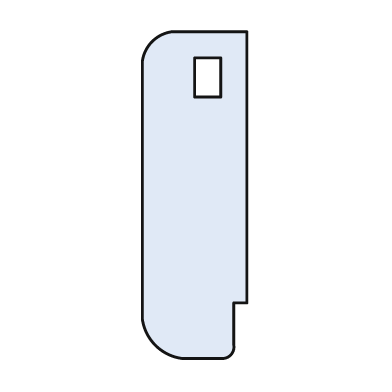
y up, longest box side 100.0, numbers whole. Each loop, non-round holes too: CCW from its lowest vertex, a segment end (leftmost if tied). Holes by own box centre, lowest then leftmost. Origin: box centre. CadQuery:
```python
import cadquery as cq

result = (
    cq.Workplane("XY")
    .moveTo(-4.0, -50.0)
    .lineTo(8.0, -50.0)
    .threePointArc((11.0, -49.0), (12.0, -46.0))
    .lineTo(12.0, -33.0)
    .lineTo(16.0, -33.0)
    .lineTo(16.0, 50.0)
    .lineTo(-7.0, 50.0)
    .threePointArc((-13.0, 47.0), (-16.0, 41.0))
    .lineTo(-16.0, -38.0)
    .threePointArc((-12.0, -46.0), (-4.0, -50.0))
    .close()
    .moveTo(0.0, 30.0)
    .lineTo(8.0, 30.0)
    .lineTo(8.0, 42.0)
    .lineTo(0.0, 42.0)
    .close()
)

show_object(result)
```